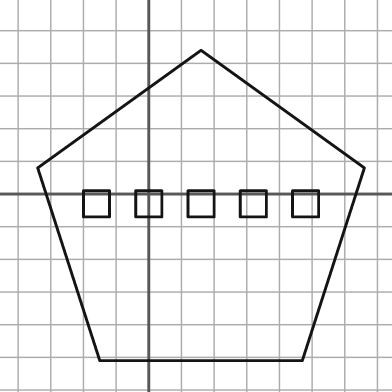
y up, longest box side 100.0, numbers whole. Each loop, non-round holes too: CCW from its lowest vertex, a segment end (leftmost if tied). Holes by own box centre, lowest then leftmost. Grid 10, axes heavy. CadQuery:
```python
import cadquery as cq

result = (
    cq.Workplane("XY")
    .moveTo(-15.0, -51.0)
    .lineTo(47.0, -51.0)
    .lineTo(66.0, 8.0)
    .lineTo(16.0, 44.0)
    .lineTo(-34.0, 8.0)
    .close()
    .moveTo(-20.0, -7.0)
    .lineTo(-12.0, -7.0)
    .lineTo(-12.0, 1.0)
    .lineTo(-20.0, 1.0)
    .close()
    .moveTo(-4.0, -7.0)
    .lineTo(4.0, -7.0)
    .lineTo(4.0, 1.0)
    .lineTo(-4.0, 1.0)
    .close()
    .moveTo(12.0, -7.0)
    .lineTo(20.0, -7.0)
    .lineTo(20.0, 1.0)
    .lineTo(12.0, 1.0)
    .close()
    .moveTo(28.0, -7.0)
    .lineTo(36.0, -7.0)
    .lineTo(36.0, 1.0)
    .lineTo(28.0, 1.0)
    .close()
    .moveTo(44.0, -7.0)
    .lineTo(52.0, -7.0)
    .lineTo(52.0, 1.0)
    .lineTo(44.0, 1.0)
    .close()
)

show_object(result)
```